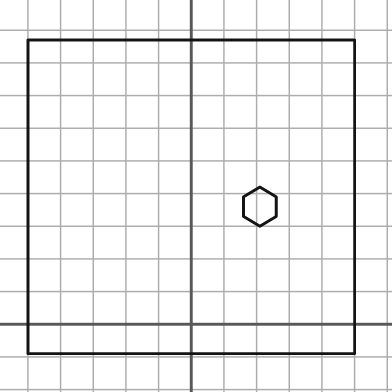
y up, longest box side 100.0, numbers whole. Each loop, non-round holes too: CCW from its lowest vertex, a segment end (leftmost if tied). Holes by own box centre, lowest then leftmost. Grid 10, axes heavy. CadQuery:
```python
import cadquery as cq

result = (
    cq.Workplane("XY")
    .moveTo(-50.0, -9.0)
    .lineTo(50.0, -9.0)
    .lineTo(50.0, 87.0)
    .lineTo(-50.0, 87.0)
    .close()
    .moveTo(21.0, 30.0)
    .lineTo(26.0, 33.0)
    .lineTo(26.0, 39.0)
    .lineTo(21.0, 42.0)
    .lineTo(16.0, 39.0)
    .lineTo(16.0, 33.0)
    .close()
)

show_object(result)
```